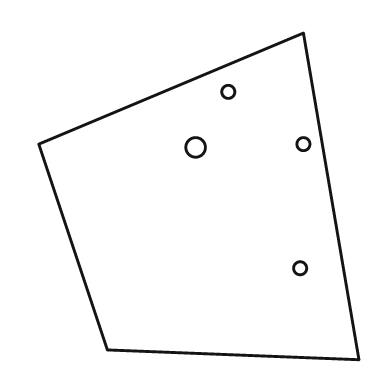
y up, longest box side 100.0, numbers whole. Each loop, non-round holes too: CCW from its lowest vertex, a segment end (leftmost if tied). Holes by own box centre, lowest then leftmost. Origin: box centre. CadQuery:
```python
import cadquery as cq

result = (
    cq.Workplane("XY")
    .moveTo(49.0, -50.0)
    .lineTo(32.0, 50.0)
    .lineTo(-49.0, 16.0)
    .lineTo(-28.0, -47.0)
    .close()
    .moveTo(31.0, -22.0)
    .circle(2.0)
    .moveTo(-1.0, 15.0)
    .circle(3.0)
    .moveTo(32.0, 16.0)
    .circle(2.0)
    .moveTo(9.0, 32.0)
    .circle(2.0)
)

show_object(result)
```